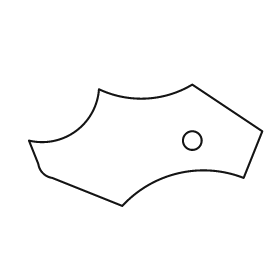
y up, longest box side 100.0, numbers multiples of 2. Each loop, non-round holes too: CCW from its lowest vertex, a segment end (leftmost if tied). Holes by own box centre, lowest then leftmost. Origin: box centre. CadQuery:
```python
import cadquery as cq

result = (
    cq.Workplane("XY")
    .moveTo(-10.0, -26.0)
    .threePointArc((14.0, -12.0), (42.0, -14.0))
    .lineTo(50.0, 6.0)
    .lineTo(20.0, 26.0)
    .threePointArc((0.0, 20.0), (-20.0, 24.0))
    .threePointArc((-30.0, 6.0), (-50.0, 2.0))
    .lineTo(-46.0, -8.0)
    .threePointArc((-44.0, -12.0), (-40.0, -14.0))
    .close()
    .moveTo(20.0, 2.0)
    .circle(4.0)
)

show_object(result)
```